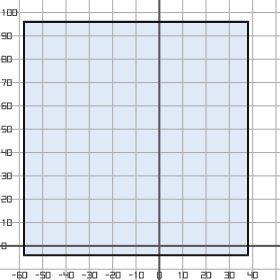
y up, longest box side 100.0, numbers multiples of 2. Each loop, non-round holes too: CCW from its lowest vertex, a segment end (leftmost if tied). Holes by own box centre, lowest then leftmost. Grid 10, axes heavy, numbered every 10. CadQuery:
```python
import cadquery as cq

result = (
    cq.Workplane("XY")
    .moveTo(-58.0, -4.0)
    .lineTo(38.0, -4.0)
    .lineTo(38.0, 96.0)
    .lineTo(-58.0, 96.0)
    .close()
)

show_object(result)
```